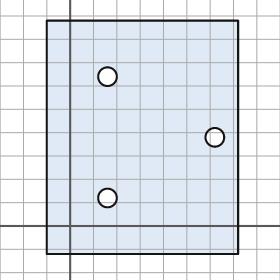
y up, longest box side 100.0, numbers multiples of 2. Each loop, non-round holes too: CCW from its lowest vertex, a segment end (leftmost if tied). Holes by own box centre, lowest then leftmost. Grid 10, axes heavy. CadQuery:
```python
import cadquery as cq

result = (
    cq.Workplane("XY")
    .moveTo(-10.0, -12.0)
    .lineTo(72.0, -12.0)
    .lineTo(72.0, 88.0)
    .lineTo(-10.0, 88.0)
    .close()
    .moveTo(16.0, 12.0)
    .circle(4.0)
    .moveTo(62.0, 38.0)
    .circle(4.0)
    .moveTo(16.0, 64.0)
    .circle(4.0)
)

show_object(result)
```